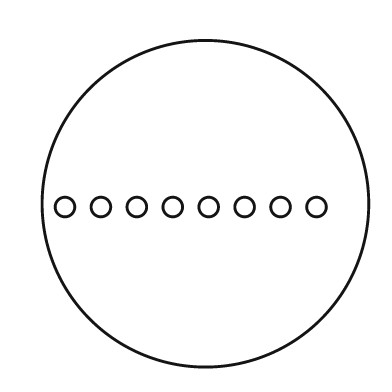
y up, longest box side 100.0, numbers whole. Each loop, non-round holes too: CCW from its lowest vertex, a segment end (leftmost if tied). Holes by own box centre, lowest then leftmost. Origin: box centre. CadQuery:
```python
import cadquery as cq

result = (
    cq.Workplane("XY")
    .moveTo(0.0, 0.0)
    .circle(50.0)
    .moveTo(-43.0, -1.0)
    .circle(3.0)
    .moveTo(-32.0, -1.0)
    .circle(3.0)
    .moveTo(-21.0, -1.0)
    .circle(3.0)
    .moveTo(-10.0, -1.0)
    .circle(3.0)
    .moveTo(1.0, -1.0)
    .circle(3.0)
    .moveTo(12.0, -1.0)
    .circle(3.0)
    .moveTo(23.0, -1.0)
    .circle(3.0)
    .moveTo(34.0, -1.0)
    .circle(3.0)
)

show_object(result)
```